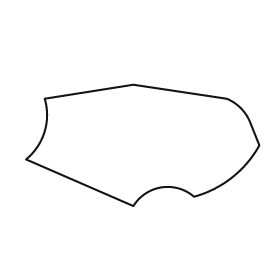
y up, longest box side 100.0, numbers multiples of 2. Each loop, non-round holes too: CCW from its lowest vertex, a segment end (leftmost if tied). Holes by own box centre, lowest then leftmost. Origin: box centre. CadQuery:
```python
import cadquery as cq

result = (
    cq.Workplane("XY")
    .moveTo(-4.0, -26.0)
    .threePointArc((8.0, -18.0), (22.0, -22.0))
    .threePointArc((38.0, -14.0), (50.0, 0.0))
    .lineTo(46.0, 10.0)
    .threePointArc((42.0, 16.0), (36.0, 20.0))
    .lineTo(-4.0, 26.0)
    .lineTo(-42.0, 20.0)
    .threePointArc((-42.0, 6.0), (-50.0, -6.0))
    .close()
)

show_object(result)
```